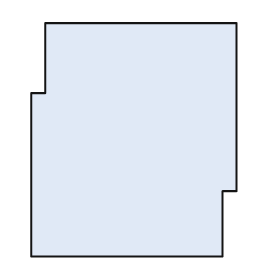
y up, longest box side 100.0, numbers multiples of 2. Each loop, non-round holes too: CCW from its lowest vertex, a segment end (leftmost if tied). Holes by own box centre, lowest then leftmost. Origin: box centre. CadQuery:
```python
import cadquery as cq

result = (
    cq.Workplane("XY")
    .moveTo(-44.0, -50.0)
    .lineTo(38.0, -50.0)
    .lineTo(38.0, -22.0)
    .lineTo(44.0, -22.0)
    .lineTo(44.0, 50.0)
    .lineTo(-38.0, 50.0)
    .lineTo(-38.0, 20.0)
    .lineTo(-44.0, 20.0)
    .close()
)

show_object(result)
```